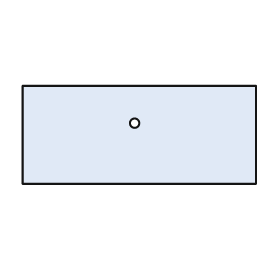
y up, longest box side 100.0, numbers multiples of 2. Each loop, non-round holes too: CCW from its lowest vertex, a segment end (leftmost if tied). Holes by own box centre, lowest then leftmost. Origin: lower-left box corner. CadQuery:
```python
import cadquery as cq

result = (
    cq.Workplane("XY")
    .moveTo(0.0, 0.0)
    .lineTo(100.0, 0.0)
    .lineTo(100.0, 42.0)
    .lineTo(0.0, 42.0)
    .close()
    .moveTo(48.0, 26.0)
    .circle(2.0)
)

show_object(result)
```